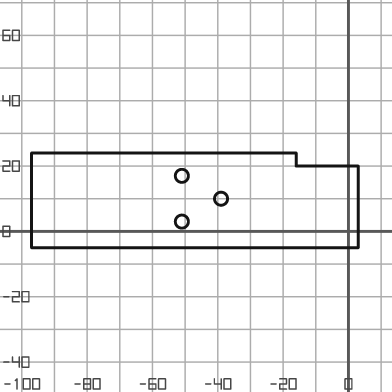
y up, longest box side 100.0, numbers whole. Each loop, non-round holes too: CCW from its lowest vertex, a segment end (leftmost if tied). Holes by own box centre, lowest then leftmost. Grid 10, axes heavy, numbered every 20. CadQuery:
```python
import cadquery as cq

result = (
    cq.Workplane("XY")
    .moveTo(-97.0, -5.0)
    .lineTo(3.0, -5.0)
    .lineTo(3.0, 20.0)
    .lineTo(-16.0, 20.0)
    .lineTo(-16.0, 24.0)
    .lineTo(-97.0, 24.0)
    .close()
    .moveTo(-51.0, 3.0)
    .circle(2.0)
    .moveTo(-39.0, 10.0)
    .circle(2.0)
    .moveTo(-51.0, 17.0)
    .circle(2.0)
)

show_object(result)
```